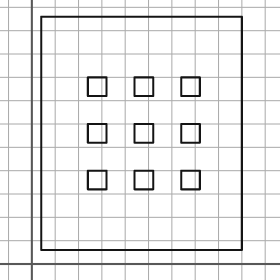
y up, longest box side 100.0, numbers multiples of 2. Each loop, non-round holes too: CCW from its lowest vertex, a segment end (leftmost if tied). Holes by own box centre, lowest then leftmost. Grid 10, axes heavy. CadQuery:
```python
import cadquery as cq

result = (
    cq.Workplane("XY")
    .moveTo(4.0, 6.0)
    .lineTo(90.0, 6.0)
    .lineTo(90.0, 106.0)
    .lineTo(4.0, 106.0)
    .close()
    .moveTo(24.0, 32.0)
    .lineTo(32.0, 32.0)
    .lineTo(32.0, 40.0)
    .lineTo(24.0, 40.0)
    .close()
    .moveTo(44.0, 32.0)
    .lineTo(52.0, 32.0)
    .lineTo(52.0, 40.0)
    .lineTo(44.0, 40.0)
    .close()
    .moveTo(64.0, 32.0)
    .lineTo(72.0, 32.0)
    .lineTo(72.0, 40.0)
    .lineTo(64.0, 40.0)
    .close()
    .moveTo(24.0, 52.0)
    .lineTo(32.0, 52.0)
    .lineTo(32.0, 60.0)
    .lineTo(24.0, 60.0)
    .close()
    .moveTo(44.0, 52.0)
    .lineTo(52.0, 52.0)
    .lineTo(52.0, 60.0)
    .lineTo(44.0, 60.0)
    .close()
    .moveTo(64.0, 52.0)
    .lineTo(72.0, 52.0)
    .lineTo(72.0, 60.0)
    .lineTo(64.0, 60.0)
    .close()
    .moveTo(24.0, 72.0)
    .lineTo(32.0, 72.0)
    .lineTo(32.0, 80.0)
    .lineTo(24.0, 80.0)
    .close()
    .moveTo(44.0, 72.0)
    .lineTo(52.0, 72.0)
    .lineTo(52.0, 80.0)
    .lineTo(44.0, 80.0)
    .close()
    .moveTo(64.0, 72.0)
    .lineTo(72.0, 72.0)
    .lineTo(72.0, 80.0)
    .lineTo(64.0, 80.0)
    .close()
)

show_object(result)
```